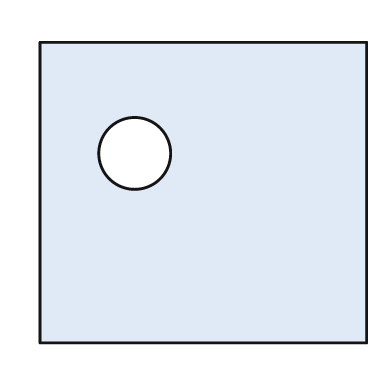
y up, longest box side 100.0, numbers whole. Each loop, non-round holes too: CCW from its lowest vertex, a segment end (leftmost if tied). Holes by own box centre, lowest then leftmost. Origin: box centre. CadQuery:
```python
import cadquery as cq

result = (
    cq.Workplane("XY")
    .moveTo(-50.0, -46.0)
    .lineTo(50.0, -46.0)
    .lineTo(50.0, 46.0)
    .lineTo(-50.0, 46.0)
    .close()
    .moveTo(-21.0, 12.0)
    .circle(11.0)
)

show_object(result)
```